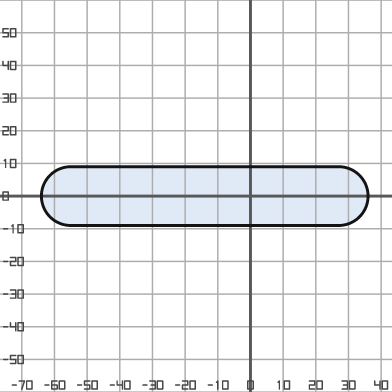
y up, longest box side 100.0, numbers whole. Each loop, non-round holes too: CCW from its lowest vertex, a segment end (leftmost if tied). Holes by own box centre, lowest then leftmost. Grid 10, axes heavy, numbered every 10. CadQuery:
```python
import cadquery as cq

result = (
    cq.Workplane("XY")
    .moveTo(-55.0, -9.0)
    .lineTo(27.0, -9.0)
    .threePointArc((36.0, 0.0), (27.0, 9.0))
    .lineTo(-55.0, 9.0)
    .threePointArc((-64.0, 0.0), (-55.0, -9.0))
    .close()
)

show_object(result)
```